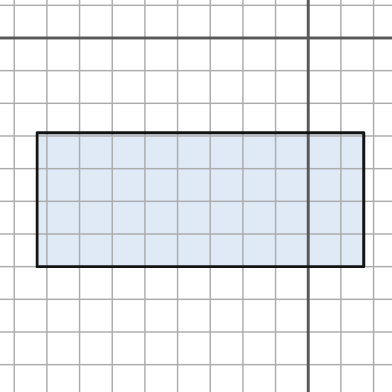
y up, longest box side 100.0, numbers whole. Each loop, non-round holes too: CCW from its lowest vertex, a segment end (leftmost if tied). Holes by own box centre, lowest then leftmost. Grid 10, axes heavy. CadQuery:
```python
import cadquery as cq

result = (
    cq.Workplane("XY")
    .moveTo(-83.0, -70.0)
    .lineTo(17.0, -70.0)
    .lineTo(17.0, -29.0)
    .lineTo(-83.0, -29.0)
    .close()
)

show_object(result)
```